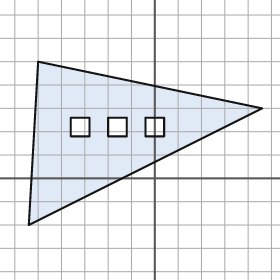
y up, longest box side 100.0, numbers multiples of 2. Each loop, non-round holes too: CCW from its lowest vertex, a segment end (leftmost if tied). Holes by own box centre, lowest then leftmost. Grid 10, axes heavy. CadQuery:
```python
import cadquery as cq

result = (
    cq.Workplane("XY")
    .moveTo(-54.0, -20.0)
    .lineTo(46.0, 30.0)
    .lineTo(-50.0, 50.0)
    .close()
    .moveTo(-36.0, 18.0)
    .lineTo(-28.0, 18.0)
    .lineTo(-28.0, 26.0)
    .lineTo(-36.0, 26.0)
    .close()
    .moveTo(-20.0, 18.0)
    .lineTo(-12.0, 18.0)
    .lineTo(-12.0, 26.0)
    .lineTo(-20.0, 26.0)
    .close()
    .moveTo(-4.0, 18.0)
    .lineTo(4.0, 18.0)
    .lineTo(4.0, 26.0)
    .lineTo(-4.0, 26.0)
    .close()
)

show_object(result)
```